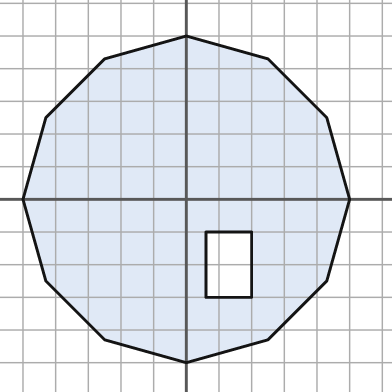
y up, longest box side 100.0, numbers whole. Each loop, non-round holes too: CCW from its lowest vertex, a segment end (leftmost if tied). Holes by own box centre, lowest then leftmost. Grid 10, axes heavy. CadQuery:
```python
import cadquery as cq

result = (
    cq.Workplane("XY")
    .moveTo(0.0, -50.0)
    .lineTo(25.0, -43.0)
    .lineTo(43.0, -25.0)
    .lineTo(50.0, 0.0)
    .lineTo(43.0, 25.0)
    .lineTo(25.0, 43.0)
    .lineTo(0.0, 50.0)
    .lineTo(-25.0, 43.0)
    .lineTo(-43.0, 25.0)
    .lineTo(-50.0, 0.0)
    .lineTo(-43.0, -25.0)
    .lineTo(-25.0, -43.0)
    .close()
    .moveTo(6.0, -30.0)
    .lineTo(20.0, -30.0)
    .lineTo(20.0, -10.0)
    .lineTo(6.0, -10.0)
    .close()
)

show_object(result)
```